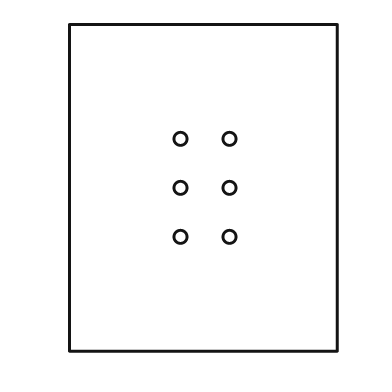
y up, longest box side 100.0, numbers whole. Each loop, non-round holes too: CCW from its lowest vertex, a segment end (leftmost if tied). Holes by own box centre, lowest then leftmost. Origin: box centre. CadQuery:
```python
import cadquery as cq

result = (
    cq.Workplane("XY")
    .moveTo(-41.0, -50.0)
    .lineTo(41.0, -50.0)
    .lineTo(41.0, 50.0)
    .lineTo(-41.0, 50.0)
    .close()
    .moveTo(-7.0, -15.0)
    .circle(2.0)
    .moveTo(8.0, -15.0)
    .circle(2.0)
    .moveTo(-7.0, 0.0)
    .circle(2.0)
    .moveTo(8.0, 0.0)
    .circle(2.0)
    .moveTo(-7.0, 15.0)
    .circle(2.0)
    .moveTo(8.0, 15.0)
    .circle(2.0)
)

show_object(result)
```